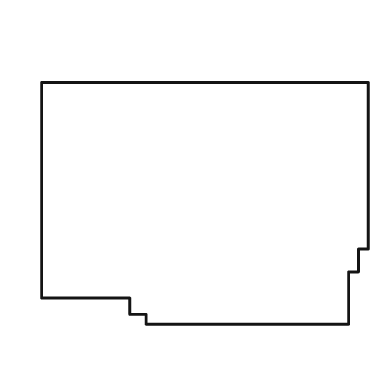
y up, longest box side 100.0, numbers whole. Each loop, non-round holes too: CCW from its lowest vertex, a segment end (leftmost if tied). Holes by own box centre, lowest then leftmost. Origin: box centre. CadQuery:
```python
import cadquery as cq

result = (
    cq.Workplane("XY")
    .moveTo(-18.0, -37.0)
    .lineTo(44.0, -37.0)
    .lineTo(44.0, -21.0)
    .lineTo(47.0, -21.0)
    .lineTo(47.0, -14.0)
    .lineTo(50.0, -14.0)
    .lineTo(50.0, 37.0)
    .lineTo(-50.0, 37.0)
    .lineTo(-50.0, -29.0)
    .lineTo(-23.0, -29.0)
    .lineTo(-23.0, -34.0)
    .lineTo(-18.0, -34.0)
    .close()
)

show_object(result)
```